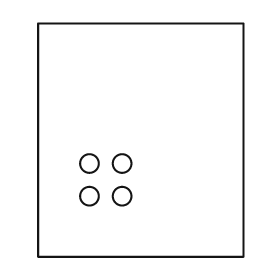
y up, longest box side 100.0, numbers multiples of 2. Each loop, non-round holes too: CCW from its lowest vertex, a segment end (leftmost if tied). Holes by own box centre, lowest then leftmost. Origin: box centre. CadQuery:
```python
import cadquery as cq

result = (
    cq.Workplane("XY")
    .moveTo(-44.0, -50.0)
    .lineTo(44.0, -50.0)
    .lineTo(44.0, 50.0)
    .lineTo(-44.0, 50.0)
    .close()
    .moveTo(-22.0, -24.0)
    .circle(4.0)
    .moveTo(-8.0, -24.0)
    .circle(4.0)
    .moveTo(-22.0, -10.0)
    .circle(4.0)
    .moveTo(-8.0, -10.0)
    .circle(4.0)
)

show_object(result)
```